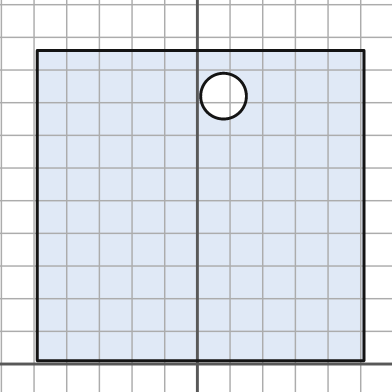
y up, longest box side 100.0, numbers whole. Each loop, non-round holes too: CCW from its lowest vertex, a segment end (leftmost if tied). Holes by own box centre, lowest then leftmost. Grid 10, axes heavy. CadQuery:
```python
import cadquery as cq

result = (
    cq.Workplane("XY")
    .moveTo(-49.0, 1.0)
    .lineTo(51.0, 1.0)
    .lineTo(51.0, 96.0)
    .lineTo(-49.0, 96.0)
    .close()
    .moveTo(8.0, 82.0)
    .circle(7.0)
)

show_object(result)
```